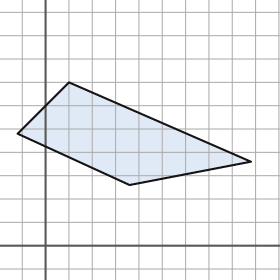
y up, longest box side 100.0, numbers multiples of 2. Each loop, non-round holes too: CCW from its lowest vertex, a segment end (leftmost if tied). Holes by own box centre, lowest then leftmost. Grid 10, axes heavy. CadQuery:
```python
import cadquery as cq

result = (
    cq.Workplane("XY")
    .moveTo(36.0, 26.0)
    .lineTo(88.0, 36.0)
    .lineTo(10.0, 70.0)
    .lineTo(-12.0, 48.0)
    .close()
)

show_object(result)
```